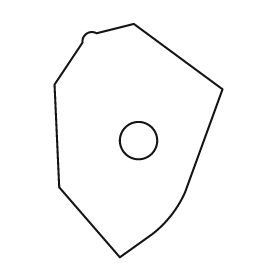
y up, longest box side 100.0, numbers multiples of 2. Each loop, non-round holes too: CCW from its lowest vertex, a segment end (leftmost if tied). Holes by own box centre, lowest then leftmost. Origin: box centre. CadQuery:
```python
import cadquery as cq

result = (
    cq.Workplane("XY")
    .moveTo(-8.0, -50.0)
    .lineTo(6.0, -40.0)
    .threePointArc((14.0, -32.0), (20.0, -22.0))
    .lineTo(36.0, 22.0)
    .lineTo(-2.0, 50.0)
    .lineTo(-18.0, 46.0)
    .threePointArc((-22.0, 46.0), (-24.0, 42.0))
    .lineTo(-36.0, 24.0)
    .lineTo(-34.0, -20.0)
    .close()
    .moveTo(0.0, 0.0)
    .circle(8.0)
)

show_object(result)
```